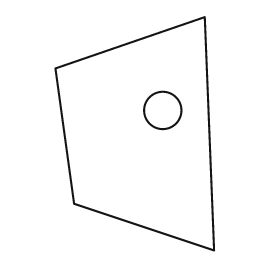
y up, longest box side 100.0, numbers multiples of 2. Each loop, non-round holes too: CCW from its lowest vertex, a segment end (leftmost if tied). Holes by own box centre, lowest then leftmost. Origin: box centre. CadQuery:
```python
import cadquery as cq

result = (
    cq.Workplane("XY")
    .moveTo(34.0, -50.0)
    .lineTo(30.0, 50.0)
    .lineTo(-34.0, 28.0)
    .lineTo(-26.0, -30.0)
    .close()
    .moveTo(12.0, 10.0)
    .circle(8.0)
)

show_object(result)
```